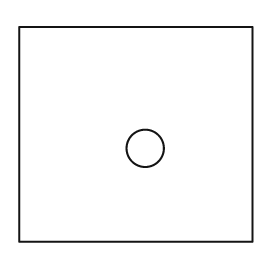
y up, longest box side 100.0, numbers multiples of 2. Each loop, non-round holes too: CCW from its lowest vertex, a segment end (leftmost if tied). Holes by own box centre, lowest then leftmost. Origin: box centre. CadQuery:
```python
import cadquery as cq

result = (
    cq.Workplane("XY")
    .moveTo(-50.0, -46.0)
    .lineTo(50.0, -46.0)
    .lineTo(50.0, 46.0)
    .lineTo(-50.0, 46.0)
    .close()
    .moveTo(4.0, -6.0)
    .circle(8.0)
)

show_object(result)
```